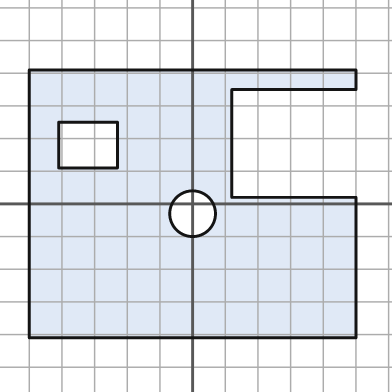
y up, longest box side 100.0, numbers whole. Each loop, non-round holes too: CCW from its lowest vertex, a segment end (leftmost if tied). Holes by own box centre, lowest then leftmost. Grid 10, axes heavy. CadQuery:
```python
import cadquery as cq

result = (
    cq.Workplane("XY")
    .moveTo(-50.0, -41.0)
    .lineTo(50.0, -41.0)
    .lineTo(50.0, 2.0)
    .lineTo(12.0, 2.0)
    .lineTo(12.0, 35.0)
    .lineTo(50.0, 35.0)
    .lineTo(50.0, 41.0)
    .lineTo(-50.0, 41.0)
    .close()
    .moveTo(0.0, -3.0)
    .circle(7.0)
    .moveTo(-41.0, 11.0)
    .lineTo(-23.0, 11.0)
    .lineTo(-23.0, 25.0)
    .lineTo(-41.0, 25.0)
    .close()
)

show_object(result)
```